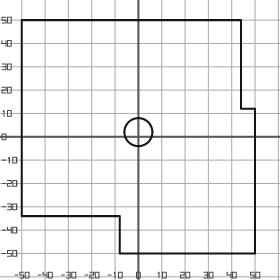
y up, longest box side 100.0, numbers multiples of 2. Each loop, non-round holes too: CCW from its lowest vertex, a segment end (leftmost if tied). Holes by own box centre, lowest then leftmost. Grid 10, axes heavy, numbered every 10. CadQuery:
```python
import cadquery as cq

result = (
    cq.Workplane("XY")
    .moveTo(-8.0, -50.0)
    .lineTo(50.0, -50.0)
    .lineTo(50.0, 12.0)
    .lineTo(44.0, 12.0)
    .lineTo(44.0, 50.0)
    .lineTo(-50.0, 50.0)
    .lineTo(-50.0, -34.0)
    .lineTo(-8.0, -34.0)
    .close()
    .moveTo(0.0, 2.0)
    .circle(6.0)
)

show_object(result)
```